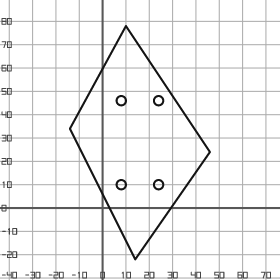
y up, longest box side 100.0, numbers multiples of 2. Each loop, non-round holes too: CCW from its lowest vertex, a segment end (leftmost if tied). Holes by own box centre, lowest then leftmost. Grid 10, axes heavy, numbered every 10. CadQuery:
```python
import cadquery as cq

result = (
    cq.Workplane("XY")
    .moveTo(14.0, -22.0)
    .lineTo(46.0, 24.0)
    .lineTo(10.0, 78.0)
    .lineTo(-14.0, 34.0)
    .close()
    .moveTo(8.0, 10.0)
    .circle(2.0)
    .moveTo(24.0, 10.0)
    .circle(2.0)
    .moveTo(8.0, 46.0)
    .circle(2.0)
    .moveTo(24.0, 46.0)
    .circle(2.0)
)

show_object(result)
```